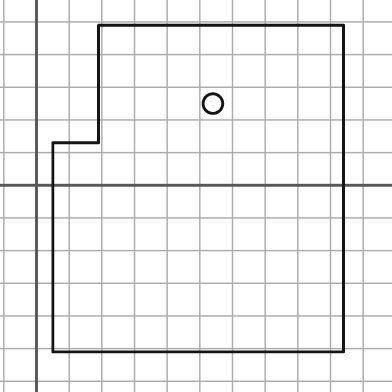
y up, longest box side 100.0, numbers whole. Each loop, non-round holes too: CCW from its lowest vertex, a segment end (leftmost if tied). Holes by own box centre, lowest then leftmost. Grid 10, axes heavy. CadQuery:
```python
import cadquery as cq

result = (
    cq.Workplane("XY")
    .moveTo(5.0, -51.0)
    .lineTo(94.0, -51.0)
    .lineTo(94.0, 49.0)
    .lineTo(19.0, 49.0)
    .lineTo(19.0, 13.0)
    .lineTo(5.0, 13.0)
    .close()
    .moveTo(54.0, 25.0)
    .circle(3.0)
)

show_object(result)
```